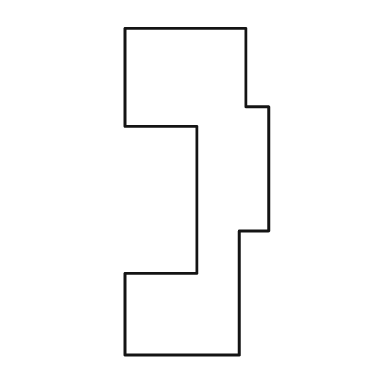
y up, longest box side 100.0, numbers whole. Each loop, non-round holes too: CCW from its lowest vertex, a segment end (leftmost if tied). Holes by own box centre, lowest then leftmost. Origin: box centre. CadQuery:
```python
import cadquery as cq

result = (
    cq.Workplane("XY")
    .moveTo(-22.0, -50.0)
    .lineTo(13.0, -50.0)
    .lineTo(13.0, -12.0)
    .lineTo(22.0, -12.0)
    .lineTo(22.0, 26.0)
    .lineTo(15.0, 26.0)
    .lineTo(15.0, 50.0)
    .lineTo(-22.0, 50.0)
    .lineTo(-22.0, 20.0)
    .lineTo(0.0, 20.0)
    .lineTo(0.0, -25.0)
    .lineTo(-22.0, -25.0)
    .close()
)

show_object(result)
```